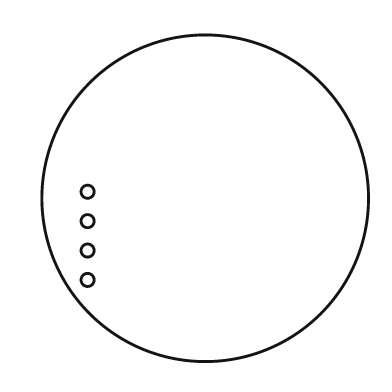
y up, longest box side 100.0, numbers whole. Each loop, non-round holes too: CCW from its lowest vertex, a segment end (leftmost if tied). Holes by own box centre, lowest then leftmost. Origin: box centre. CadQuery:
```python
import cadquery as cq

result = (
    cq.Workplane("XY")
    .moveTo(0.0, 0.0)
    .circle(50.0)
    .moveTo(-36.0, -25.0)
    .circle(2.0)
    .moveTo(-36.0, -16.0)
    .circle(2.0)
    .moveTo(-36.0, -7.0)
    .circle(2.0)
    .moveTo(-36.0, 2.0)
    .circle(2.0)
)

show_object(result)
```